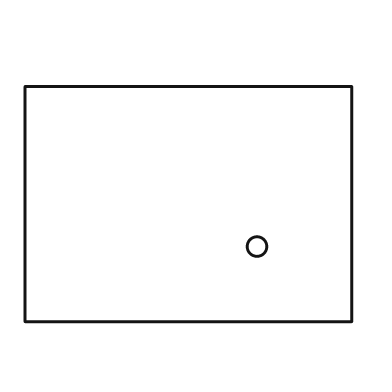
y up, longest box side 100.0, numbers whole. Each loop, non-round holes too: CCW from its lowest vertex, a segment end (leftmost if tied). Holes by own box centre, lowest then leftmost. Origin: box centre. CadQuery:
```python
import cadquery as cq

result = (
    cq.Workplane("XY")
    .moveTo(-50.0, -36.0)
    .lineTo(50.0, -36.0)
    .lineTo(50.0, 36.0)
    .lineTo(-50.0, 36.0)
    .close()
    .moveTo(21.0, -13.0)
    .circle(3.0)
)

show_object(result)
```